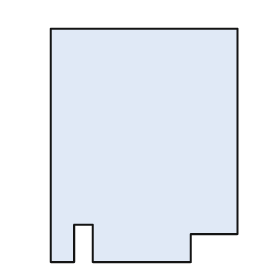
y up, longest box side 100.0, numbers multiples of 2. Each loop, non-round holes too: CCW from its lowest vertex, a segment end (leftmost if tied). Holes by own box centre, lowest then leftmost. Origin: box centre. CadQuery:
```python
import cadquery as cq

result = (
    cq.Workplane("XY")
    .moveTo(-40.0, -50.0)
    .lineTo(-30.0, -50.0)
    .lineTo(-30.0, -34.0)
    .lineTo(-22.0, -34.0)
    .lineTo(-22.0, -50.0)
    .lineTo(20.0, -50.0)
    .lineTo(20.0, -38.0)
    .lineTo(40.0, -38.0)
    .lineTo(40.0, 50.0)
    .lineTo(-40.0, 50.0)
    .close()
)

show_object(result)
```